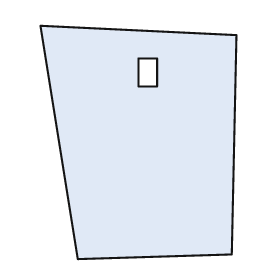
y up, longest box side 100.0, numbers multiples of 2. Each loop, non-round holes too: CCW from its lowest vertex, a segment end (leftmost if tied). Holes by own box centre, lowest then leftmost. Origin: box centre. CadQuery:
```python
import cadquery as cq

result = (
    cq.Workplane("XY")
    .moveTo(-26.0, -50.0)
    .lineTo(40.0, -48.0)
    .lineTo(42.0, 46.0)
    .lineTo(-42.0, 50.0)
    .close()
    .moveTo(0.0, 24.0)
    .lineTo(8.0, 24.0)
    .lineTo(8.0, 36.0)
    .lineTo(0.0, 36.0)
    .close()
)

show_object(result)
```